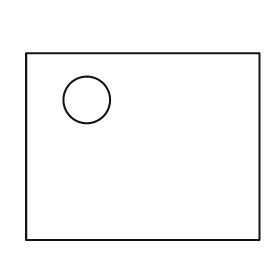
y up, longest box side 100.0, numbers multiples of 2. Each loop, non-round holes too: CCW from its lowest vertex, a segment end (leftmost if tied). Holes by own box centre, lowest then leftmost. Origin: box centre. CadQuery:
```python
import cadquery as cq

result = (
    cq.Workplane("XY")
    .moveTo(-50.0, -40.0)
    .lineTo(50.0, -40.0)
    .lineTo(50.0, 40.0)
    .lineTo(-50.0, 40.0)
    .close()
    .moveTo(-24.0, 20.0)
    .circle(10.0)
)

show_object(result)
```